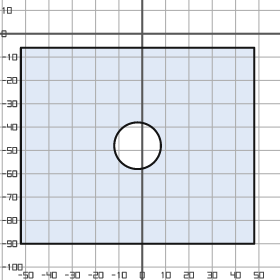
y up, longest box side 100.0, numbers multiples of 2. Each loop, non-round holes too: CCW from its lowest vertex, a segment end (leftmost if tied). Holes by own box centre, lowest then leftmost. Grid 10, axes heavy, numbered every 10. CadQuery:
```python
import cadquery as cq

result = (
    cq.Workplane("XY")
    .moveTo(-52.0, -90.0)
    .lineTo(48.0, -90.0)
    .lineTo(48.0, -6.0)
    .lineTo(-52.0, -6.0)
    .close()
    .moveTo(-2.0, -48.0)
    .circle(10.0)
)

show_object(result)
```